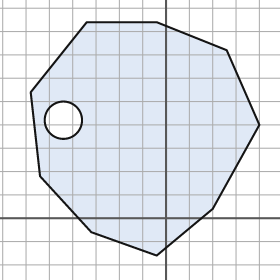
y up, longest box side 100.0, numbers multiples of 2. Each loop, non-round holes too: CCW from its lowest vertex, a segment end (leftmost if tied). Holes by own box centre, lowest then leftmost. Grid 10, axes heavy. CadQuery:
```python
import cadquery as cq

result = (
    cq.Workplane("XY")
    .moveTo(-4.0, -16.0)
    .lineTo(20.0, 4.0)
    .lineTo(40.0, 40.0)
    .lineTo(26.0, 72.0)
    .lineTo(-4.0, 84.0)
    .lineTo(-34.0, 84.0)
    .lineTo(-58.0, 54.0)
    .lineTo(-54.0, 18.0)
    .lineTo(-32.0, -6.0)
    .close()
    .moveTo(-44.0, 42.0)
    .circle(8.0)
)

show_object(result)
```